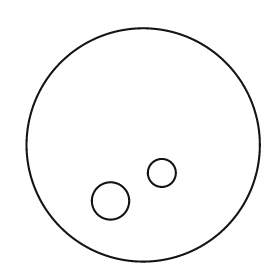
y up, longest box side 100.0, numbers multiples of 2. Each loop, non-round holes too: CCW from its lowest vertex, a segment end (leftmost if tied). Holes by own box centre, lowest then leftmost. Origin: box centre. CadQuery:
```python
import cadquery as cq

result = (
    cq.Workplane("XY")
    .moveTo(0.0, 0.0)
    .circle(50.0)
    .moveTo(-14.0, -24.0)
    .circle(8.0)
    .moveTo(8.0, -12.0)
    .circle(6.0)
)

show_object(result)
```